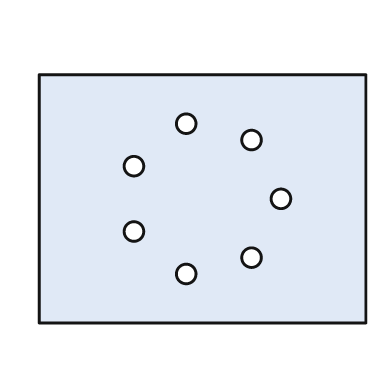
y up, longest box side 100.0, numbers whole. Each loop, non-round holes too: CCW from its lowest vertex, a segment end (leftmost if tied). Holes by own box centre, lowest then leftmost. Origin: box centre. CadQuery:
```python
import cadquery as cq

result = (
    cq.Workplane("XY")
    .moveTo(-50.0, -38.0)
    .lineTo(50.0, -38.0)
    .lineTo(50.0, 38.0)
    .lineTo(-50.0, 38.0)
    .close()
    .moveTo(-5.0, -23.0)
    .circle(3.0)
    .moveTo(15.0, -18.0)
    .circle(3.0)
    .moveTo(-21.0, -10.0)
    .circle(3.0)
    .moveTo(24.0, 0.0)
    .circle(3.0)
    .moveTo(-21.0, 10.0)
    .circle(3.0)
    .moveTo(15.0, 18.0)
    .circle(3.0)
    .moveTo(-5.0, 23.0)
    .circle(3.0)
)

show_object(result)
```